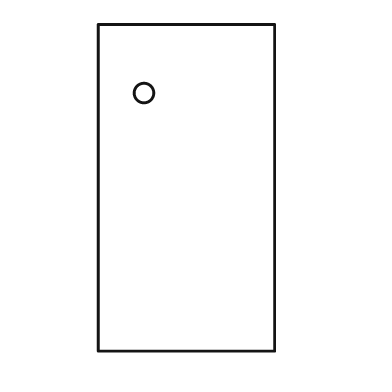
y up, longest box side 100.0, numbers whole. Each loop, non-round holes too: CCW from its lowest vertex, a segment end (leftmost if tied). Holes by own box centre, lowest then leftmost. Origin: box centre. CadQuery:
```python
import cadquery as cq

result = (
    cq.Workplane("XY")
    .moveTo(-27.0, -50.0)
    .lineTo(27.0, -50.0)
    .lineTo(27.0, 50.0)
    .lineTo(-27.0, 50.0)
    .close()
    .moveTo(-13.0, 29.0)
    .circle(3.0)
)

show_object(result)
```